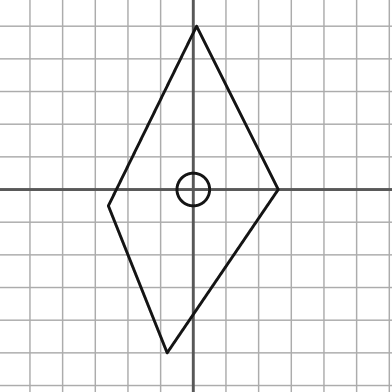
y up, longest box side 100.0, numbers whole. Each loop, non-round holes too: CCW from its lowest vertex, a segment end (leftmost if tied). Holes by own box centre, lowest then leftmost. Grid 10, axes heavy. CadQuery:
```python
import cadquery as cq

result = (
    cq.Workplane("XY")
    .moveTo(-8.0, -50.0)
    .lineTo(26.0, 0.0)
    .lineTo(1.0, 50.0)
    .lineTo(-26.0, -5.0)
    .close()
    .moveTo(0.0, 0.0)
    .circle(5.0)
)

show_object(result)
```